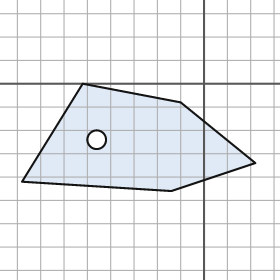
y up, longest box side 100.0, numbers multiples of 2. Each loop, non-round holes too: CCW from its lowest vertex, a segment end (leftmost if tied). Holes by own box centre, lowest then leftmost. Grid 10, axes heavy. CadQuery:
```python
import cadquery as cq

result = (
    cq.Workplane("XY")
    .moveTo(-14.0, -46.0)
    .lineTo(22.0, -34.0)
    .lineTo(-10.0, -8.0)
    .lineTo(-52.0, 0.0)
    .lineTo(-78.0, -42.0)
    .close()
    .moveTo(-46.0, -24.0)
    .circle(4.0)
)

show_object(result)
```